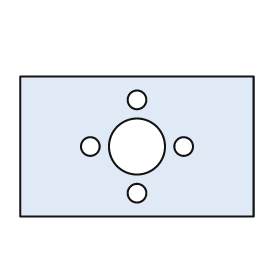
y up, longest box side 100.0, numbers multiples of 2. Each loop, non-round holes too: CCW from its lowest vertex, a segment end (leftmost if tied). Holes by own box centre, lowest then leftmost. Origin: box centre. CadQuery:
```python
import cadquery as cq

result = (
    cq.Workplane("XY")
    .moveTo(-50.0, -30.0)
    .lineTo(50.0, -30.0)
    .lineTo(50.0, 30.0)
    .lineTo(-50.0, 30.0)
    .close()
    .moveTo(0.0, -20.0)
    .circle(4.0)
    .moveTo(-20.0, 0.0)
    .circle(4.0)
    .moveTo(0.0, 0.0)
    .circle(12.0)
    .moveTo(20.0, 0.0)
    .circle(4.0)
    .moveTo(0.0, 20.0)
    .circle(4.0)
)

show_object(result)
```